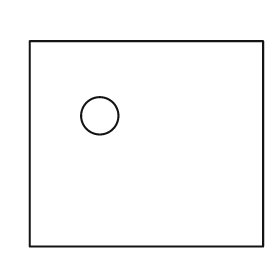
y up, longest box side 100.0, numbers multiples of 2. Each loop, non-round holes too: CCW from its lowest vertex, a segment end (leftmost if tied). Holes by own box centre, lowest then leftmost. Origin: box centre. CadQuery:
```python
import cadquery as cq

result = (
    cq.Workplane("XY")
    .moveTo(-50.0, -44.0)
    .lineTo(50.0, -44.0)
    .lineTo(50.0, 44.0)
    .lineTo(-50.0, 44.0)
    .close()
    .moveTo(-20.0, 12.0)
    .circle(8.0)
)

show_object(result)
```